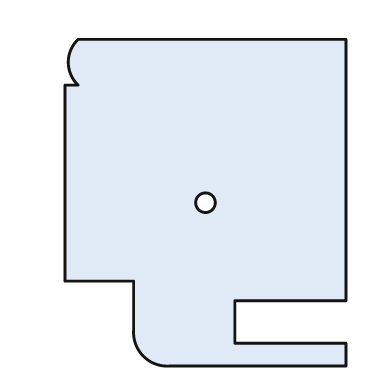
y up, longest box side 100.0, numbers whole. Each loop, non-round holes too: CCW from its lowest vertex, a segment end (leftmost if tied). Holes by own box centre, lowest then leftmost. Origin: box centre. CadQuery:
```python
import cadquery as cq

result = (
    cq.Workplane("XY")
    .moveTo(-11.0, -50.0)
    .lineTo(43.0, -50.0)
    .lineTo(43.0, -43.0)
    .lineTo(9.0, -43.0)
    .lineTo(9.0, -30.0)
    .lineTo(43.0, -30.0)
    .lineTo(43.0, 50.0)
    .lineTo(-39.0, 50.0)
    .threePointArc((-42.0, 43.0), (-39.0, 36.0))
    .lineTo(-43.0, 36.0)
    .lineTo(-43.0, -24.0)
    .lineTo(-22.0, -24.0)
    .lineTo(-22.0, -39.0)
    .threePointArc((-19.0, -47.0), (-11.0, -50.0))
    .close()
    .moveTo(0.0, 0.0)
    .circle(3.0)
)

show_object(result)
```